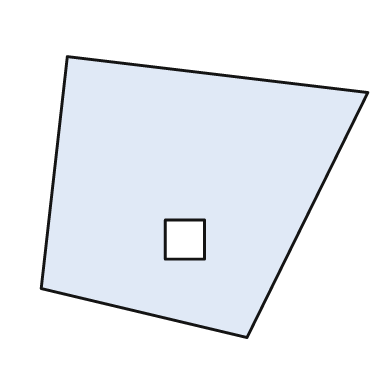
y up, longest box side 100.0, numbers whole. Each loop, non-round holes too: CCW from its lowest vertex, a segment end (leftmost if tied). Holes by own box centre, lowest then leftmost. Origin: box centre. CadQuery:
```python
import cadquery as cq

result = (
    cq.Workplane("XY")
    .moveTo(13.0, -43.0)
    .lineTo(50.0, 32.0)
    .lineTo(-42.0, 43.0)
    .lineTo(-50.0, -28.0)
    .close()
    .moveTo(-12.0, -19.0)
    .lineTo(0.0, -19.0)
    .lineTo(0.0, -7.0)
    .lineTo(-12.0, -7.0)
    .close()
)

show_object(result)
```